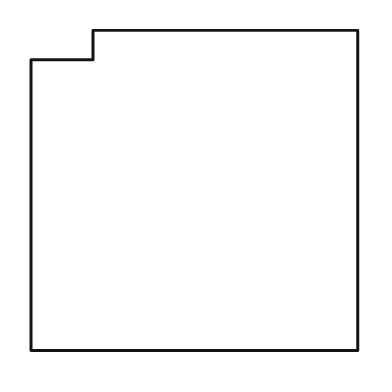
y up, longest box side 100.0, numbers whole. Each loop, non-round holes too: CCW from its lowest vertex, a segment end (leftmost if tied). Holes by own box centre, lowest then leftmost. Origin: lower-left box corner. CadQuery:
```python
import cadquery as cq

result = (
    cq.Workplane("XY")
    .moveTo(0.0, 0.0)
    .lineTo(100.0, 0.0)
    .lineTo(100.0, 98.0)
    .lineTo(19.0, 98.0)
    .lineTo(19.0, 89.0)
    .lineTo(0.0, 89.0)
    .close()
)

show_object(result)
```